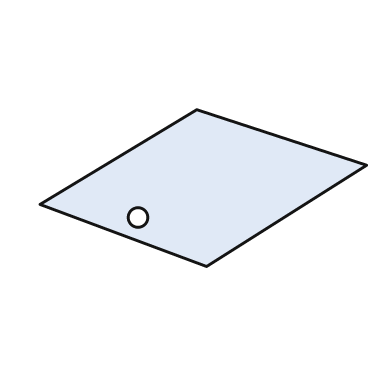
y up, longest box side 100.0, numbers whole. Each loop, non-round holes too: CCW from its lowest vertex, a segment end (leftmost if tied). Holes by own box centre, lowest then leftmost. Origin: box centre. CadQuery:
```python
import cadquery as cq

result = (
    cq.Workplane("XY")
    .moveTo(1.0, -24.0)
    .lineTo(50.0, 7.0)
    .lineTo(-2.0, 24.0)
    .lineTo(-50.0, -5.0)
    .close()
    .moveTo(-20.0, -9.0)
    .circle(3.0)
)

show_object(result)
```